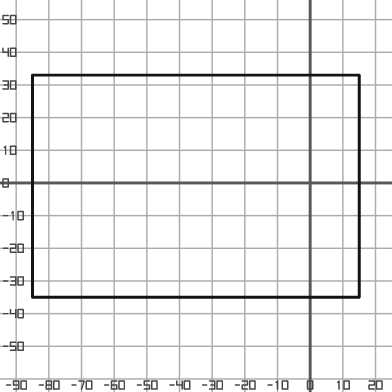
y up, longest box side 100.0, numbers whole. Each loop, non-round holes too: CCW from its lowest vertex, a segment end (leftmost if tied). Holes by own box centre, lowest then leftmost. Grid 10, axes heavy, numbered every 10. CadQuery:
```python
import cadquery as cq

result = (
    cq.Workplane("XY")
    .moveTo(-85.0, -35.0)
    .lineTo(15.0, -35.0)
    .lineTo(15.0, 33.0)
    .lineTo(-85.0, 33.0)
    .close()
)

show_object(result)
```